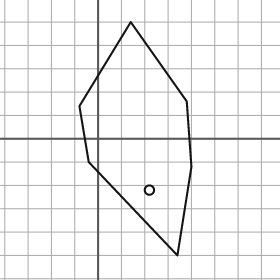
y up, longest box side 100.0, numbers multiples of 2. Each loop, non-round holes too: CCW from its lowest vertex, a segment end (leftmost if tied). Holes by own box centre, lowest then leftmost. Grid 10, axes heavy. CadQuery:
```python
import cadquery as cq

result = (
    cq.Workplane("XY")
    .moveTo(34.0, -50.0)
    .lineTo(40.0, -12.0)
    .lineTo(38.0, 16.0)
    .lineTo(14.0, 50.0)
    .lineTo(-8.0, 14.0)
    .lineTo(-4.0, -10.0)
    .close()
    .moveTo(22.0, -22.0)
    .circle(2.0)
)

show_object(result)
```